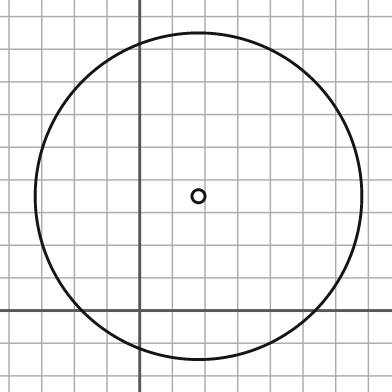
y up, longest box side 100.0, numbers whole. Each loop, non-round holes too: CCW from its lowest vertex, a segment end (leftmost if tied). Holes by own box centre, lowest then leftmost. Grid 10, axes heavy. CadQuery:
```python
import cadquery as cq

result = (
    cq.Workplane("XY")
    .moveTo(18.0, 35.0)
    .circle(50.0)
    .moveTo(18.0, 35.0)
    .circle(2.0)
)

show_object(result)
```